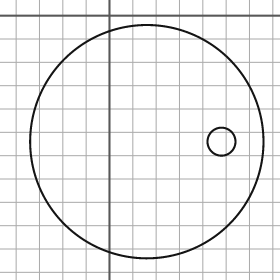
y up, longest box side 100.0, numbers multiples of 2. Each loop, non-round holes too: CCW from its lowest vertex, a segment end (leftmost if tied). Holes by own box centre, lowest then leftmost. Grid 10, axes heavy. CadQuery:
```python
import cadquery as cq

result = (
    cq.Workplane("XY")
    .moveTo(16.0, -54.0)
    .circle(50.0)
    .moveTo(48.0, -54.0)
    .circle(6.0)
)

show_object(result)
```